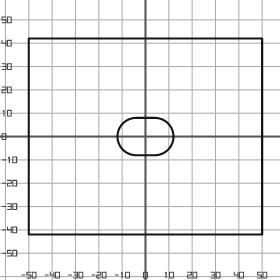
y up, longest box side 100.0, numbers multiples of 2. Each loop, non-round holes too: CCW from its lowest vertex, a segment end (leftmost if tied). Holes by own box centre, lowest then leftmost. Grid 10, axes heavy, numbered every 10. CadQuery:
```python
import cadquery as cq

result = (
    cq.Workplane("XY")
    .moveTo(-50.0, -42.0)
    .lineTo(50.0, -42.0)
    .lineTo(50.0, 42.0)
    .lineTo(-50.0, 42.0)
    .close()
    .moveTo(-4.0, -8.0)
    .lineTo(4.0, -8.0)
    .threePointArc((12.0, 0.0), (4.0, 8.0))
    .lineTo(-4.0, 8.0)
    .threePointArc((-12.0, 0.0), (-4.0, -8.0))
    .close()
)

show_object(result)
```